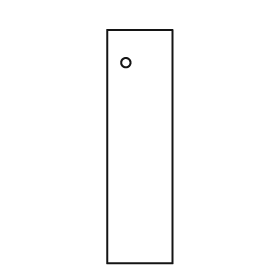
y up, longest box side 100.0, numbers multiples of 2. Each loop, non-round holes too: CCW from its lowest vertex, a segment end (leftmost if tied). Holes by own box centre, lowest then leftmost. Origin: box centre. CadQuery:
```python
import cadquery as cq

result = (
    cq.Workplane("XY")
    .moveTo(-14.0, -50.0)
    .lineTo(14.0, -50.0)
    .lineTo(14.0, 50.0)
    .lineTo(-14.0, 50.0)
    .close()
    .moveTo(-6.0, 36.0)
    .circle(2.0)
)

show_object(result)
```